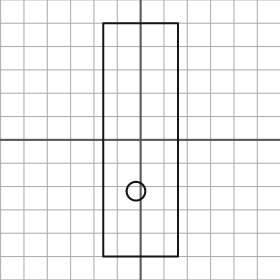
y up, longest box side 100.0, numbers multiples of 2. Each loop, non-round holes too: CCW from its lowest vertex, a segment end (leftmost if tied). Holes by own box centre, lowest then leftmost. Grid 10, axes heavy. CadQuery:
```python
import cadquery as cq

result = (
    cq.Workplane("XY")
    .moveTo(-16.0, -50.0)
    .lineTo(16.0, -50.0)
    .lineTo(16.0, 50.0)
    .lineTo(-16.0, 50.0)
    .close()
    .moveTo(-2.0, -22.0)
    .circle(4.0)
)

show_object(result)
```